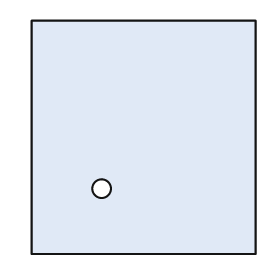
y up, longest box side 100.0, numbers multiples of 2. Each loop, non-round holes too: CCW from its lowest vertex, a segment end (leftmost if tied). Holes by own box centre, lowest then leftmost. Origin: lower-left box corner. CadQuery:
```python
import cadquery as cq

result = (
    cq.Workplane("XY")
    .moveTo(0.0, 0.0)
    .lineTo(96.0, 0.0)
    .lineTo(96.0, 100.0)
    .lineTo(0.0, 100.0)
    .close()
    .moveTo(30.0, 28.0)
    .circle(4.0)
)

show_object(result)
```